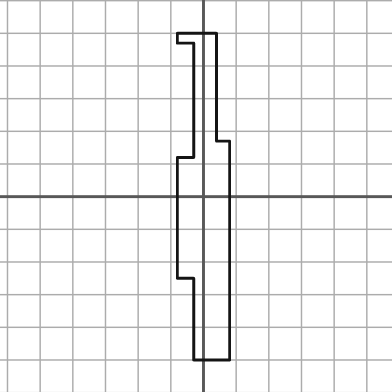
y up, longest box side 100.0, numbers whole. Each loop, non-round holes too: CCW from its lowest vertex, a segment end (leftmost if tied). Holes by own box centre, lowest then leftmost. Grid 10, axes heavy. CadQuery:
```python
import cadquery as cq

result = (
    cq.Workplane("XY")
    .moveTo(-3.0, -50.0)
    .lineTo(8.0, -50.0)
    .lineTo(8.0, 17.0)
    .lineTo(4.0, 17.0)
    .lineTo(4.0, 50.0)
    .lineTo(-8.0, 50.0)
    .lineTo(-8.0, 47.0)
    .lineTo(-3.0, 47.0)
    .lineTo(-3.0, 12.0)
    .lineTo(-8.0, 12.0)
    .lineTo(-8.0, -25.0)
    .lineTo(-3.0, -25.0)
    .close()
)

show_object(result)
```